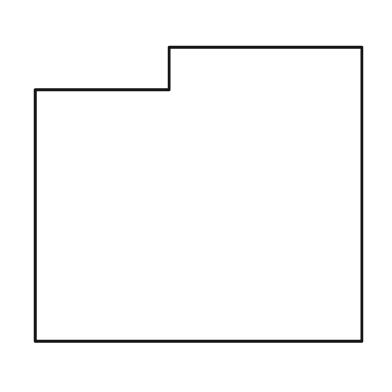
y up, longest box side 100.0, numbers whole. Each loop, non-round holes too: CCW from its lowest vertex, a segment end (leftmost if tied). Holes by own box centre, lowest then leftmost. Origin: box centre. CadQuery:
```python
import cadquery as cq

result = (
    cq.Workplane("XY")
    .moveTo(-50.0, -45.0)
    .lineTo(50.0, -45.0)
    .lineTo(50.0, 45.0)
    .lineTo(-9.0, 45.0)
    .lineTo(-9.0, 32.0)
    .lineTo(-50.0, 32.0)
    .close()
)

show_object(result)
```